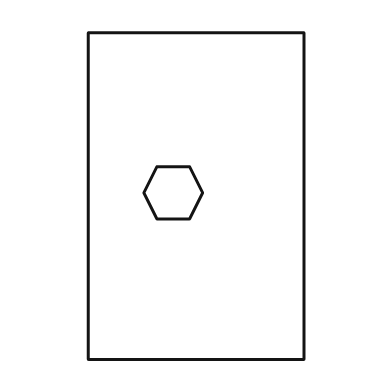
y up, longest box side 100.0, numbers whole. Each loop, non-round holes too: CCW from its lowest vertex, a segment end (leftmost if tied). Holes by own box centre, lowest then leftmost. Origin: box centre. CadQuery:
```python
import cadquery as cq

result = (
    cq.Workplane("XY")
    .moveTo(-33.0, -50.0)
    .lineTo(33.0, -50.0)
    .lineTo(33.0, 50.0)
    .lineTo(-33.0, 50.0)
    .close()
    .moveTo(-12.0, -7.0)
    .lineTo(-2.0, -7.0)
    .lineTo(2.0, 1.0)
    .lineTo(-2.0, 9.0)
    .lineTo(-12.0, 9.0)
    .lineTo(-16.0, 1.0)
    .close()
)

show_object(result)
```